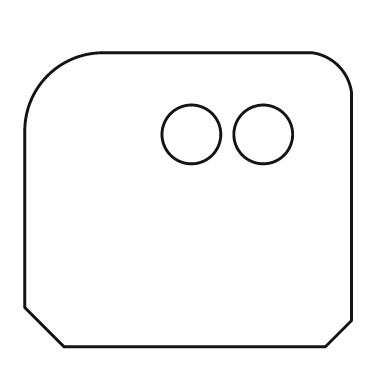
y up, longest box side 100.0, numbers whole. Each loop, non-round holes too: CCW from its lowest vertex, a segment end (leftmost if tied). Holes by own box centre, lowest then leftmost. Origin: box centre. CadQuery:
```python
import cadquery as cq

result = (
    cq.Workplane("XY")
    .moveTo(-38.0, -45.0)
    .lineTo(42.0, -45.0)
    .lineTo(50.0, -37.0)
    .lineTo(50.0, 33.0)
    .threePointArc((46.0, 41.0), (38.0, 45.0))
    .lineTo(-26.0, 45.0)
    .threePointArc((-43.0, 38.0), (-50.0, 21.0))
    .lineTo(-50.0, -33.0)
    .close()
    .moveTo(1.0, 20.0)
    .circle(9.0)
    .moveTo(23.0, 20.0)
    .circle(9.0)
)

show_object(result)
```